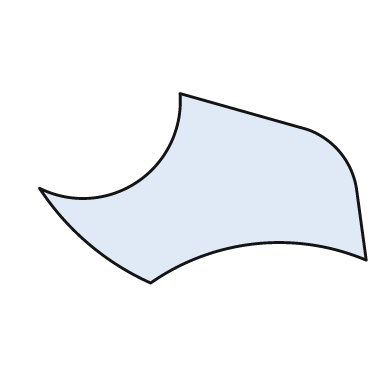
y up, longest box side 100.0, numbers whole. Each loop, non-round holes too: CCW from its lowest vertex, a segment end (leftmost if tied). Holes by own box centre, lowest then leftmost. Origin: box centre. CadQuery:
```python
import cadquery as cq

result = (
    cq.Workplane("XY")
    .moveTo(-16.0, -29.0)
    .threePointArc((16.0, -17.0), (50.0, -22.0))
    .lineTo(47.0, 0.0)
    .threePointArc((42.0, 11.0), (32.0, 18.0))
    .lineTo(-7.0, 29.0)
    .threePointArc((-20.0, 2.0), (-50.0, 0.0))
    .threePointArc((-35.0, -17.0), (-16.0, -29.0))
    .close()
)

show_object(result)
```